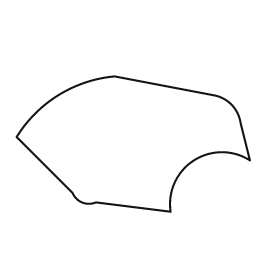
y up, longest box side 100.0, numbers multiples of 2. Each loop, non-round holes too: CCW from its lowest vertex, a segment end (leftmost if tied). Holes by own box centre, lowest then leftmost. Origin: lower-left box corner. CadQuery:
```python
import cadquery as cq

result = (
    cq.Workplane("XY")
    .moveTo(66.0, 0.0)
    .threePointArc((76.0, 22.0), (100.0, 22.0))
    .lineTo(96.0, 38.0)
    .threePointArc((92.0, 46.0), (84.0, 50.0))
    .lineTo(42.0, 58.0)
    .threePointArc((18.0, 50.0), (0.0, 32.0))
    .lineTo(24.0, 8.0)
    .threePointArc((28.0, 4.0), (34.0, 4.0))
    .close()
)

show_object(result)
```